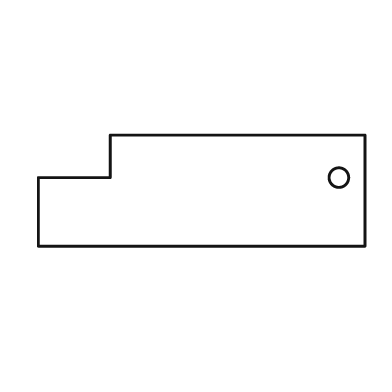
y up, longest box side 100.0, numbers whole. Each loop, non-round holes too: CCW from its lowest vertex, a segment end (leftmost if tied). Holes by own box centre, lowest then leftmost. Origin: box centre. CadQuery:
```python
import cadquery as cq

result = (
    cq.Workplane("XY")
    .moveTo(-50.0, -17.0)
    .lineTo(50.0, -17.0)
    .lineTo(50.0, 17.0)
    .lineTo(-28.0, 17.0)
    .lineTo(-28.0, 4.0)
    .lineTo(-50.0, 4.0)
    .close()
    .moveTo(42.0, 4.0)
    .circle(3.0)
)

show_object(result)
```